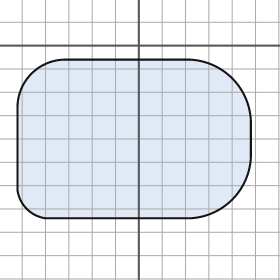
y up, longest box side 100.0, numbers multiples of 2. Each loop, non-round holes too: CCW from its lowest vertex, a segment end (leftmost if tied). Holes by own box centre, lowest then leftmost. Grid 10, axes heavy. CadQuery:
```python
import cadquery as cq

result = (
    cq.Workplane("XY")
    .moveTo(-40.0, -74.0)
    .lineTo(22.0, -74.0)
    .threePointArc((40.0, -66.0), (48.0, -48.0))
    .lineTo(48.0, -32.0)
    .threePointArc((40.0, -14.0), (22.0, -6.0))
    .lineTo(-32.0, -6.0)
    .threePointArc((-46.0, -12.0), (-52.0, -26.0))
    .lineTo(-52.0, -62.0)
    .threePointArc((-48.0, -70.0), (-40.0, -74.0))
    .close()
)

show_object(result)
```